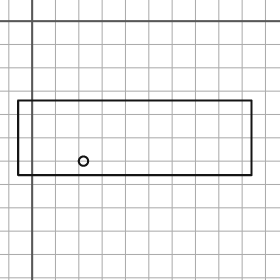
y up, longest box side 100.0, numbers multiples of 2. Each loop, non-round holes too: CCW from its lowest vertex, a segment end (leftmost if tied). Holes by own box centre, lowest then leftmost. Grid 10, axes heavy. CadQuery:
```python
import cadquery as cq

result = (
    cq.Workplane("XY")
    .moveTo(-6.0, -66.0)
    .lineTo(94.0, -66.0)
    .lineTo(94.0, -34.0)
    .lineTo(-6.0, -34.0)
    .close()
    .moveTo(22.0, -60.0)
    .circle(2.0)
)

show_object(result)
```